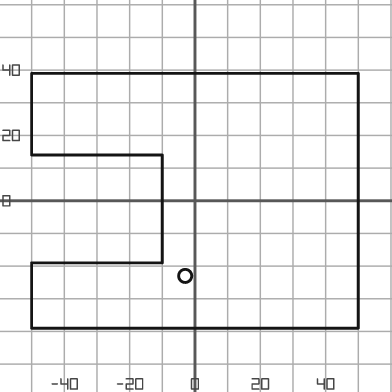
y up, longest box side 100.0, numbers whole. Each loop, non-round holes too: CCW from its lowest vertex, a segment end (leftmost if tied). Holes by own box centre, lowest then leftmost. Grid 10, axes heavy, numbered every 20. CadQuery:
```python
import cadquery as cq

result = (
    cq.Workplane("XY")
    .moveTo(-50.0, -39.0)
    .lineTo(50.0, -39.0)
    .lineTo(50.0, 39.0)
    .lineTo(-50.0, 39.0)
    .lineTo(-50.0, 14.0)
    .lineTo(-10.0, 14.0)
    .lineTo(-10.0, -19.0)
    .lineTo(-50.0, -19.0)
    .close()
    .moveTo(-3.0, -23.0)
    .circle(2.0)
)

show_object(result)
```